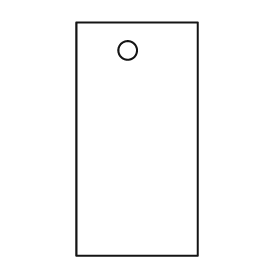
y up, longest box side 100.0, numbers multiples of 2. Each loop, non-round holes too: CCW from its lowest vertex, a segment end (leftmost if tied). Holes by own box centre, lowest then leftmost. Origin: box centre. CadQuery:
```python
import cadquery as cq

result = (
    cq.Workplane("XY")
    .moveTo(-26.0, -50.0)
    .lineTo(26.0, -50.0)
    .lineTo(26.0, 50.0)
    .lineTo(-26.0, 50.0)
    .close()
    .moveTo(-4.0, 38.0)
    .circle(4.0)
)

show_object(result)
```